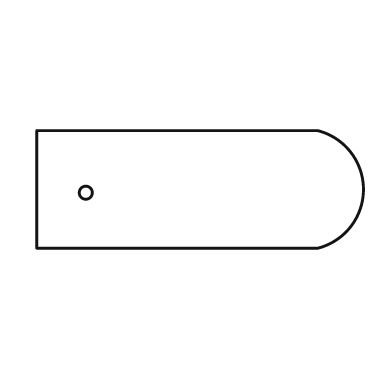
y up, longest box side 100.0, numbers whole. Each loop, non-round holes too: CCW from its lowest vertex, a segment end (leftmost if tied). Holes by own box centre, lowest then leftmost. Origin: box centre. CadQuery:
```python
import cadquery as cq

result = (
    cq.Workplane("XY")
    .moveTo(-50.0, -18.0)
    .lineTo(36.0, -18.0)
    .threePointArc((50.0, 0.0), (36.0, 18.0))
    .lineTo(-50.0, 18.0)
    .close()
    .moveTo(-35.0, -1.0)
    .circle(2.0)
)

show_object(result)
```